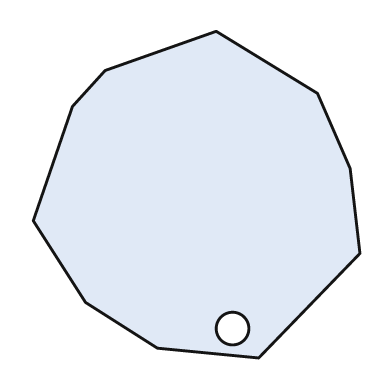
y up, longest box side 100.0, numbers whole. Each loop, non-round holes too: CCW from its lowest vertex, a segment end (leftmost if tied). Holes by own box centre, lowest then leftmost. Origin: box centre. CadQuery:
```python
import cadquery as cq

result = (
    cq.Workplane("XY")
    .moveTo(19.0, -50.0)
    .lineTo(50.0, -18.0)
    .lineTo(47.0, 8.0)
    .lineTo(37.0, 31.0)
    .lineTo(6.0, 50.0)
    .lineTo(-28.0, 38.0)
    .lineTo(-38.0, 27.0)
    .lineTo(-50.0, -8.0)
    .lineTo(-34.0, -33.0)
    .lineTo(-12.0, -47.0)
    .close()
    .moveTo(11.0, -41.0)
    .circle(5.0)
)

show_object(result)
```